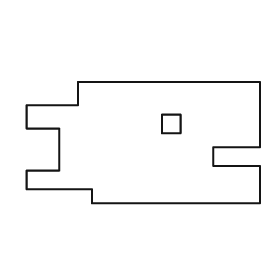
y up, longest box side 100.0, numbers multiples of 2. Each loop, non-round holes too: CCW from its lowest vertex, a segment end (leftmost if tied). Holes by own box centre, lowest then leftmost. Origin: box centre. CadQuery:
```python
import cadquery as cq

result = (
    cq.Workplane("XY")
    .moveTo(-22.0, -26.0)
    .lineTo(50.0, -26.0)
    .lineTo(50.0, -10.0)
    .lineTo(30.0, -10.0)
    .lineTo(30.0, -2.0)
    .lineTo(50.0, -2.0)
    .lineTo(50.0, 26.0)
    .lineTo(-28.0, 26.0)
    .lineTo(-28.0, 16.0)
    .lineTo(-50.0, 16.0)
    .lineTo(-50.0, 6.0)
    .lineTo(-36.0, 6.0)
    .lineTo(-36.0, -12.0)
    .lineTo(-50.0, -12.0)
    .lineTo(-50.0, -20.0)
    .lineTo(-22.0, -20.0)
    .close()
    .moveTo(8.0, 4.0)
    .lineTo(16.0, 4.0)
    .lineTo(16.0, 12.0)
    .lineTo(8.0, 12.0)
    .close()
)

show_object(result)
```